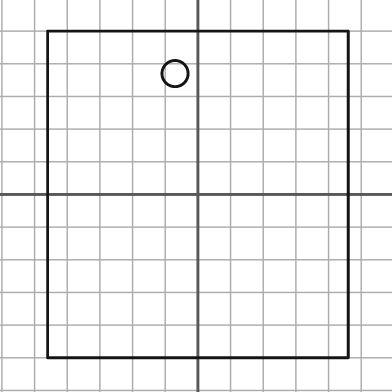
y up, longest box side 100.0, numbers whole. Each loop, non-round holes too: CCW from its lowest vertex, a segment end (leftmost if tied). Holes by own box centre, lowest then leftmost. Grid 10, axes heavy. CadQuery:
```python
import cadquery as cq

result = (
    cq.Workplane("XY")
    .moveTo(-46.0, -50.0)
    .lineTo(46.0, -50.0)
    .lineTo(46.0, 50.0)
    .lineTo(-46.0, 50.0)
    .close()
    .moveTo(-7.0, 37.0)
    .circle(4.0)
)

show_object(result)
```